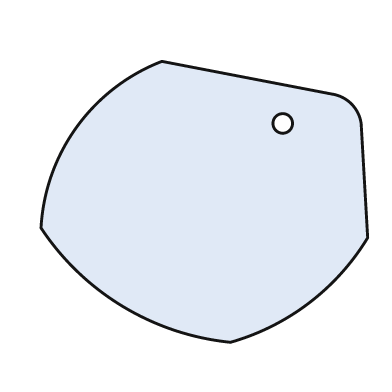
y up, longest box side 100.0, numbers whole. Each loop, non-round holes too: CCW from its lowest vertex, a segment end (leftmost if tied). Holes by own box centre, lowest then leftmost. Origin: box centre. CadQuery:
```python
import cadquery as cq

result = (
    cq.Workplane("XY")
    .moveTo(8.0, -43.0)
    .threePointArc((32.0, -31.0), (50.0, -11.0))
    .lineTo(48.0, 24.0)
    .threePointArc((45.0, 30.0), (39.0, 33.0))
    .lineTo(-13.0, 43.0)
    .threePointArc((-39.0, 23.0), (-50.0, -8.0))
    .threePointArc((-25.0, -32.0), (8.0, -43.0))
    .close()
    .moveTo(24.0, 24.0)
    .circle(3.0)
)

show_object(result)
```